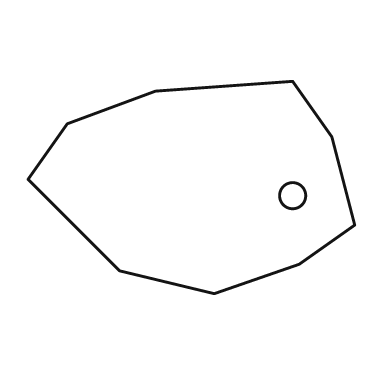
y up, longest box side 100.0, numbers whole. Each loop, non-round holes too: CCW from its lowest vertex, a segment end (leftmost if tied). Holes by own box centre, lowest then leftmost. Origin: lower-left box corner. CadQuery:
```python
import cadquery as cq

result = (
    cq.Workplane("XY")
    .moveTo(57.0, 0.0)
    .lineTo(83.0, 9.0)
    .lineTo(100.0, 21.0)
    .lineTo(93.0, 48.0)
    .lineTo(81.0, 65.0)
    .lineTo(39.0, 62.0)
    .lineTo(12.0, 52.0)
    .lineTo(0.0, 35.0)
    .lineTo(28.0, 7.0)
    .close()
    .moveTo(81.0, 30.0)
    .circle(4.0)
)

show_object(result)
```